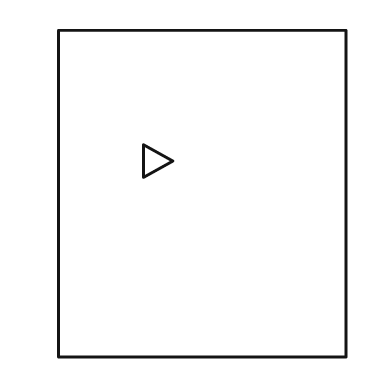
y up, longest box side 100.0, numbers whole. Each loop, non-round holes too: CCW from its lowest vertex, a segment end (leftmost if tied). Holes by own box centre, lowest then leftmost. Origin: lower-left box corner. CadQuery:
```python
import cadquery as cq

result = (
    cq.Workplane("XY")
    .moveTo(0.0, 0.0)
    .lineTo(88.0, 0.0)
    .lineTo(88.0, 100.0)
    .lineTo(0.0, 100.0)
    .close()
    .moveTo(26.0, 55.0)
    .lineTo(35.0, 60.0)
    .lineTo(26.0, 65.0)
    .close()
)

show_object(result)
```